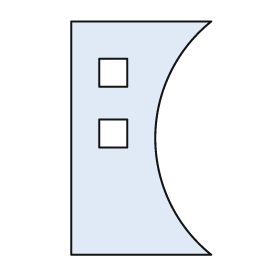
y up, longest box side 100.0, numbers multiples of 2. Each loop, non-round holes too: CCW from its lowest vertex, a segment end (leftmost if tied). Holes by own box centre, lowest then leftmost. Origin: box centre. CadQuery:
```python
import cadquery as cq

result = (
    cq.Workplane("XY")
    .moveTo(-30.0, -50.0)
    .lineTo(30.0, -50.0)
    .threePointArc((6.0, 0.0), (30.0, 50.0))
    .lineTo(-30.0, 50.0)
    .close()
    .moveTo(-18.0, -4.0)
    .lineTo(-6.0, -4.0)
    .lineTo(-6.0, 8.0)
    .lineTo(-18.0, 8.0)
    .close()
    .moveTo(-18.0, 22.0)
    .lineTo(-6.0, 22.0)
    .lineTo(-6.0, 34.0)
    .lineTo(-18.0, 34.0)
    .close()
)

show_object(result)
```